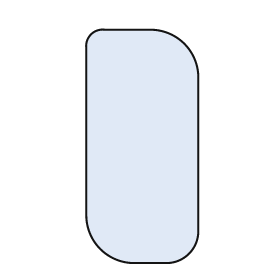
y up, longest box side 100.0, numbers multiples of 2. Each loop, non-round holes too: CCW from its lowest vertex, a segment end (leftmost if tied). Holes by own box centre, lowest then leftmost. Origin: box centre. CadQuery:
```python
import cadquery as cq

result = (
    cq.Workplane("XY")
    .moveTo(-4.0, -50.0)
    .lineTo(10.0, -50.0)
    .threePointArc((20.0, -46.0), (24.0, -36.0))
    .lineTo(24.0, 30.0)
    .threePointArc((18.0, 44.0), (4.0, 50.0))
    .lineTo(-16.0, 50.0)
    .threePointArc((-22.0, 48.0), (-24.0, 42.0))
    .lineTo(-24.0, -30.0)
    .threePointArc((-18.0, -44.0), (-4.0, -50.0))
    .close()
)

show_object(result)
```